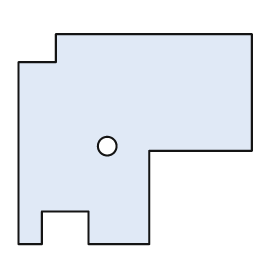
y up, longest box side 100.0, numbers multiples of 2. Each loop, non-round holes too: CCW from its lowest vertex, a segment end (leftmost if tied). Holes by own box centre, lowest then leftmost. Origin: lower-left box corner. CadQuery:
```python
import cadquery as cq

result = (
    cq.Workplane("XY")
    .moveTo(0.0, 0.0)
    .lineTo(10.0, 0.0)
    .lineTo(10.0, 14.0)
    .lineTo(30.0, 14.0)
    .lineTo(30.0, 0.0)
    .lineTo(56.0, 0.0)
    .lineTo(56.0, 40.0)
    .lineTo(100.0, 40.0)
    .lineTo(100.0, 90.0)
    .lineTo(16.0, 90.0)
    .lineTo(16.0, 78.0)
    .lineTo(0.0, 78.0)
    .close()
    .moveTo(38.0, 42.0)
    .circle(4.0)
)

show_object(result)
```